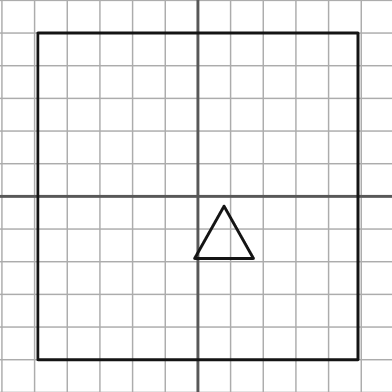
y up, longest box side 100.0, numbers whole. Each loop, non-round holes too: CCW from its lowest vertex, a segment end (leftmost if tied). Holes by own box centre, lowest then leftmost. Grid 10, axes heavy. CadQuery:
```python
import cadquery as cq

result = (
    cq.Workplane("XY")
    .moveTo(-49.0, -50.0)
    .lineTo(49.0, -50.0)
    .lineTo(49.0, 50.0)
    .lineTo(-49.0, 50.0)
    .close()
    .moveTo(-1.0, -19.0)
    .lineTo(17.0, -19.0)
    .lineTo(8.0, -3.0)
    .close()
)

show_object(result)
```